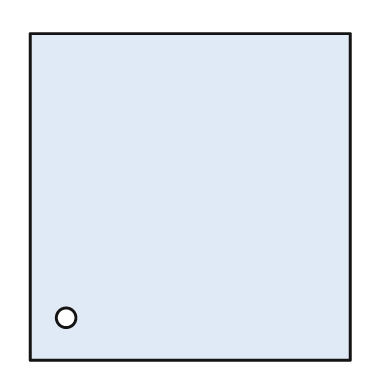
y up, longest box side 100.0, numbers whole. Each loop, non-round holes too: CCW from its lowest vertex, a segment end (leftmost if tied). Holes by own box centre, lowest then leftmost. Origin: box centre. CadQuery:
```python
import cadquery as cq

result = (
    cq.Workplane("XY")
    .moveTo(-49.0, -50.0)
    .lineTo(49.0, -50.0)
    .lineTo(49.0, 50.0)
    .lineTo(-49.0, 50.0)
    .close()
    .moveTo(-38.0, -37.0)
    .circle(3.0)
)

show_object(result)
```